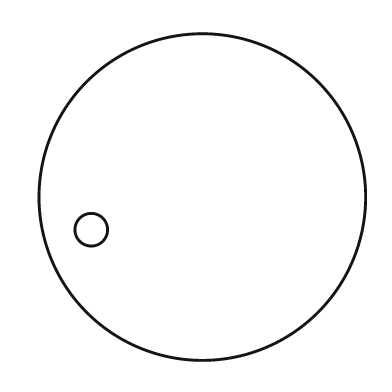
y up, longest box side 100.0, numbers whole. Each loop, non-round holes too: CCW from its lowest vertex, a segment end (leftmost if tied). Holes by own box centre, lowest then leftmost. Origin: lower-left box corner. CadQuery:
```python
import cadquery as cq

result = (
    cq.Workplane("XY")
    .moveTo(50.0, 50.0)
    .circle(50.0)
    .moveTo(16.0, 40.0)
    .circle(5.0)
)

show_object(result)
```